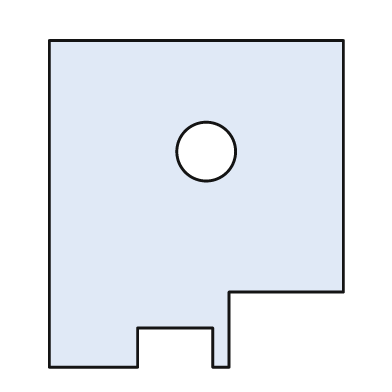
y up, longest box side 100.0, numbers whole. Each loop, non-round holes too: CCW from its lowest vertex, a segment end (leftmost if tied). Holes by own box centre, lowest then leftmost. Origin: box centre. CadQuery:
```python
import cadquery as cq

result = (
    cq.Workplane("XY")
    .moveTo(-45.0, -50.0)
    .lineTo(-18.0, -50.0)
    .lineTo(-18.0, -38.0)
    .lineTo(5.0, -38.0)
    .lineTo(5.0, -50.0)
    .lineTo(10.0, -50.0)
    .lineTo(10.0, -27.0)
    .lineTo(45.0, -27.0)
    .lineTo(45.0, 50.0)
    .lineTo(-45.0, 50.0)
    .close()
    .moveTo(3.0, 16.0)
    .circle(9.0)
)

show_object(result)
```